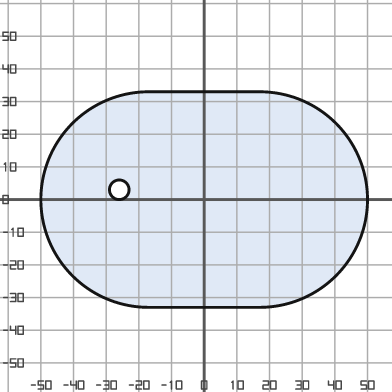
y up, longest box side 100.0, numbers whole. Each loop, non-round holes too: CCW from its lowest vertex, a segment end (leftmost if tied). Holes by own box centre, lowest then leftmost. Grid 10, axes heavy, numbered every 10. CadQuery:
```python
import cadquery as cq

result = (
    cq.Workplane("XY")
    .moveTo(-17.0, -33.0)
    .lineTo(17.0, -33.0)
    .threePointArc((50.0, 0.0), (17.0, 33.0))
    .lineTo(-17.0, 33.0)
    .threePointArc((-50.0, 0.0), (-17.0, -33.0))
    .close()
    .moveTo(-26.0, 3.0)
    .circle(3.0)
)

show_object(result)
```